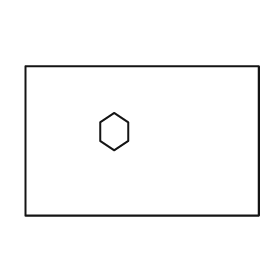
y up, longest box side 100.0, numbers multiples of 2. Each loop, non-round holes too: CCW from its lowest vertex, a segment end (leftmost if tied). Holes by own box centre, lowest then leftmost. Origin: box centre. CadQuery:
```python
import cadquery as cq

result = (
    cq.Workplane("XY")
    .moveTo(-50.0, -32.0)
    .lineTo(50.0, -32.0)
    .lineTo(50.0, 32.0)
    .lineTo(-50.0, 32.0)
    .close()
    .moveTo(-12.0, -4.0)
    .lineTo(-6.0, 0.0)
    .lineTo(-6.0, 8.0)
    .lineTo(-12.0, 12.0)
    .lineTo(-18.0, 8.0)
    .lineTo(-18.0, 0.0)
    .close()
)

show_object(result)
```